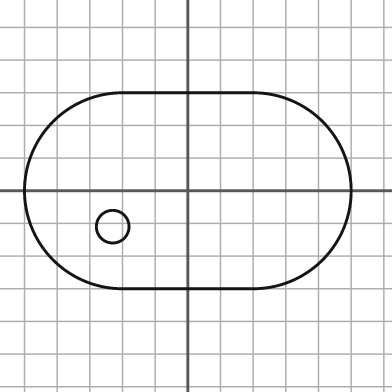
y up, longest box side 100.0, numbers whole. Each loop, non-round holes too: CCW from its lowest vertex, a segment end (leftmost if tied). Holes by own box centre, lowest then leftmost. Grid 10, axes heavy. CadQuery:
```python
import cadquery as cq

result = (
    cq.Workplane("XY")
    .moveTo(-20.0, -30.0)
    .lineTo(20.0, -30.0)
    .threePointArc((50.0, 0.0), (20.0, 30.0))
    .lineTo(-20.0, 30.0)
    .threePointArc((-50.0, 0.0), (-20.0, -30.0))
    .close()
    .moveTo(-23.0, -11.0)
    .circle(5.0)
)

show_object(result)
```